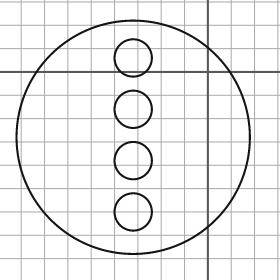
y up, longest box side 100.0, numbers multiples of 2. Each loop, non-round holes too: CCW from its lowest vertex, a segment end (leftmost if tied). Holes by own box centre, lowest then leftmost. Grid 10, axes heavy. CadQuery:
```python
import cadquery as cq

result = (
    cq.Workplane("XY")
    .moveTo(-32.0, -28.0)
    .circle(50.0)
    .moveTo(-32.0, -60.0)
    .circle(8.0)
    .moveTo(-32.0, -38.0)
    .circle(8.0)
    .moveTo(-32.0, -16.0)
    .circle(8.0)
    .moveTo(-32.0, 6.0)
    .circle(8.0)
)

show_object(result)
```